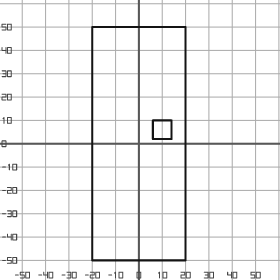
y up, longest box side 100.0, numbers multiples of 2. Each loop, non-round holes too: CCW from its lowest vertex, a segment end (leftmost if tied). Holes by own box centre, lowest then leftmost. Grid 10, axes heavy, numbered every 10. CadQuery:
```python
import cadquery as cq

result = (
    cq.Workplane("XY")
    .moveTo(-20.0, -50.0)
    .lineTo(20.0, -50.0)
    .lineTo(20.0, 50.0)
    .lineTo(-20.0, 50.0)
    .close()
    .moveTo(6.0, 2.0)
    .lineTo(14.0, 2.0)
    .lineTo(14.0, 10.0)
    .lineTo(6.0, 10.0)
    .close()
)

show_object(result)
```